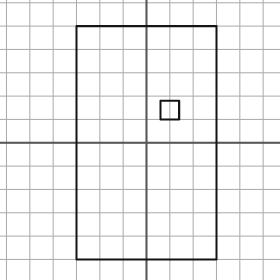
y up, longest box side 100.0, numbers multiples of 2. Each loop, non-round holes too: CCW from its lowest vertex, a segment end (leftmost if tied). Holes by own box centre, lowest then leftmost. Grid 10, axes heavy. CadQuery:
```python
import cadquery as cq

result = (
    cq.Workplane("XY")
    .moveTo(-30.0, -50.0)
    .lineTo(30.0, -50.0)
    .lineTo(30.0, 50.0)
    .lineTo(-30.0, 50.0)
    .close()
    .moveTo(6.0, 10.0)
    .lineTo(14.0, 10.0)
    .lineTo(14.0, 18.0)
    .lineTo(6.0, 18.0)
    .close()
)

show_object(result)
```